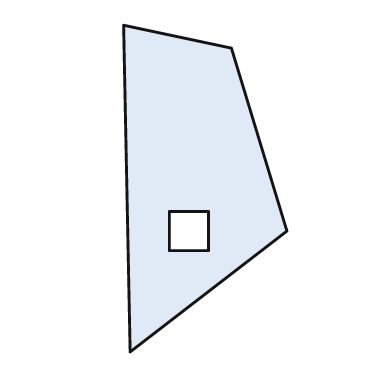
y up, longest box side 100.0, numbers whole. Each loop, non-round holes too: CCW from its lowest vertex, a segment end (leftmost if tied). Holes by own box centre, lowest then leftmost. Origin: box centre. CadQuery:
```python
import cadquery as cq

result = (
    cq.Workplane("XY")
    .moveTo(-23.0, -50.0)
    .lineTo(25.0, -13.0)
    .lineTo(8.0, 43.0)
    .lineTo(-25.0, 50.0)
    .close()
    .moveTo(-11.0, -19.0)
    .lineTo(1.0, -19.0)
    .lineTo(1.0, -7.0)
    .lineTo(-11.0, -7.0)
    .close()
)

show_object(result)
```